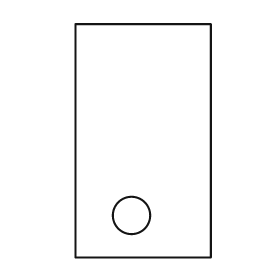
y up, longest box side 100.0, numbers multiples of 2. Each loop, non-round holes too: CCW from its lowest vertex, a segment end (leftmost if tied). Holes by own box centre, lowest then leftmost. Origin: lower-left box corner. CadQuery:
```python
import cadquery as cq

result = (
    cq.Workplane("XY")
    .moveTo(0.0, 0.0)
    .lineTo(58.0, 0.0)
    .lineTo(58.0, 100.0)
    .lineTo(0.0, 100.0)
    .close()
    .moveTo(24.0, 18.0)
    .circle(8.0)
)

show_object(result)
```